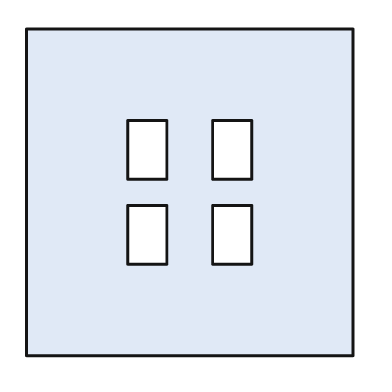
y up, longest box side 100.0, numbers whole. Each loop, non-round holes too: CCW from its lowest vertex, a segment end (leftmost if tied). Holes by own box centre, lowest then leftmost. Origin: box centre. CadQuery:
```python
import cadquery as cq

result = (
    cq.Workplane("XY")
    .moveTo(-50.0, -50.0)
    .lineTo(50.0, -50.0)
    .lineTo(50.0, 50.0)
    .lineTo(-50.0, 50.0)
    .close()
    .moveTo(-19.0, -22.0)
    .lineTo(-7.0, -22.0)
    .lineTo(-7.0, -4.0)
    .lineTo(-19.0, -4.0)
    .close()
    .moveTo(7.0, -22.0)
    .lineTo(19.0, -22.0)
    .lineTo(19.0, -4.0)
    .lineTo(7.0, -4.0)
    .close()
    .moveTo(-19.0, 4.0)
    .lineTo(-7.0, 4.0)
    .lineTo(-7.0, 22.0)
    .lineTo(-19.0, 22.0)
    .close()
    .moveTo(7.0, 4.0)
    .lineTo(19.0, 4.0)
    .lineTo(19.0, 22.0)
    .lineTo(7.0, 22.0)
    .close()
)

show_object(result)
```